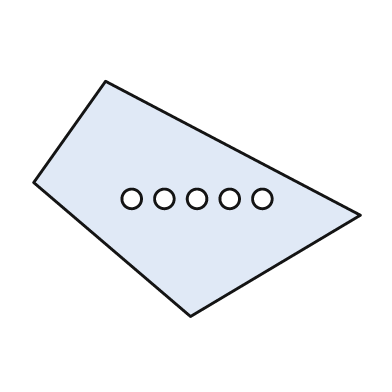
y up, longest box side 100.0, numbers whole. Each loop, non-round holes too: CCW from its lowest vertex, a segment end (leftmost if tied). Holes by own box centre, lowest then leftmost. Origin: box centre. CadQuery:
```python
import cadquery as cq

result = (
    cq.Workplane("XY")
    .moveTo(-2.0, -36.0)
    .lineTo(50.0, -5.0)
    .lineTo(-28.0, 36.0)
    .lineTo(-50.0, 5.0)
    .close()
    .moveTo(-20.0, 0.0)
    .circle(3.0)
    .moveTo(-10.0, 0.0)
    .circle(3.0)
    .moveTo(0.0, 0.0)
    .circle(3.0)
    .moveTo(10.0, 0.0)
    .circle(3.0)
    .moveTo(20.0, 0.0)
    .circle(3.0)
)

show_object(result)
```